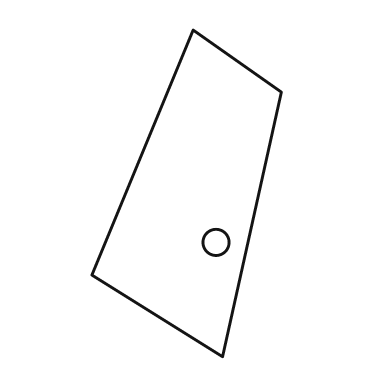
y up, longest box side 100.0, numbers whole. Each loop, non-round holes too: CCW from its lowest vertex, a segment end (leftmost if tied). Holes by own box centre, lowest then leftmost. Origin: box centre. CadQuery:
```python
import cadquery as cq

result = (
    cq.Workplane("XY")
    .moveTo(11.0, -50.0)
    .lineTo(29.0, 31.0)
    .lineTo(2.0, 50.0)
    .lineTo(-29.0, -25.0)
    .close()
    .moveTo(9.0, -15.0)
    .circle(4.0)
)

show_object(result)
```